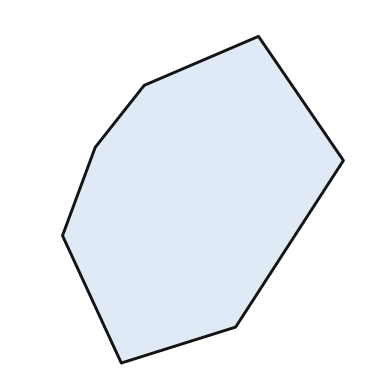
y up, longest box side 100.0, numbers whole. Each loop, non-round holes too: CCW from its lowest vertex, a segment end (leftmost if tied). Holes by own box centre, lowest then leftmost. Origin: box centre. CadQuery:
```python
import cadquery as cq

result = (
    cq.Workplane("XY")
    .moveTo(-25.0, -50.0)
    .lineTo(10.0, -39.0)
    .lineTo(43.0, 12.0)
    .lineTo(17.0, 50.0)
    .lineTo(-18.0, 35.0)
    .lineTo(-33.0, 16.0)
    .lineTo(-43.0, -11.0)
    .close()
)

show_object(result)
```